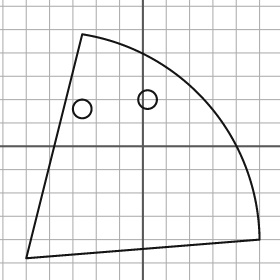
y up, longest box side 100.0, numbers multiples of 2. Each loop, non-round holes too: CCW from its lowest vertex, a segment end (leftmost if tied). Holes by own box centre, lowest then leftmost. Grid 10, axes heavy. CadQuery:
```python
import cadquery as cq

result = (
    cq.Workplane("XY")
    .moveTo(-50.0, -48.0)
    .lineTo(50.0, -40.0)
    .threePointArc((28.0, 18.0), (-26.0, 48.0))
    .close()
    .moveTo(-26.0, 16.0)
    .circle(4.0)
    .moveTo(2.0, 20.0)
    .circle(4.0)
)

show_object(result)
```